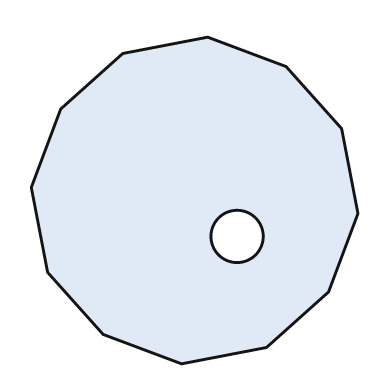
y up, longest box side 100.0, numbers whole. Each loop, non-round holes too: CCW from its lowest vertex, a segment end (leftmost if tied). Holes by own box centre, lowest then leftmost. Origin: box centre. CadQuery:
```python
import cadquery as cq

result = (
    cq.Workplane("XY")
    .moveTo(-4.0, -50.0)
    .lineTo(22.0, -45.0)
    .lineTo(41.0, -28.0)
    .lineTo(50.0, -4.0)
    .lineTo(45.0, 22.0)
    .lineTo(28.0, 41.0)
    .lineTo(4.0, 50.0)
    .lineTo(-22.0, 45.0)
    .lineTo(-41.0, 28.0)
    .lineTo(-50.0, 4.0)
    .lineTo(-45.0, -22.0)
    .lineTo(-28.0, -41.0)
    .close()
    .moveTo(13.0, -11.0)
    .circle(8.0)
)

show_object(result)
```